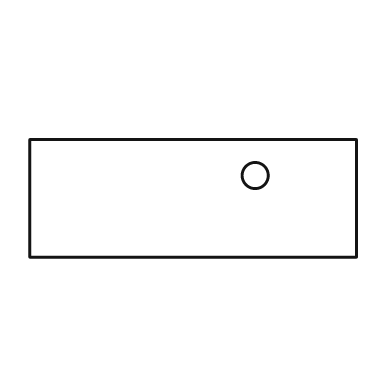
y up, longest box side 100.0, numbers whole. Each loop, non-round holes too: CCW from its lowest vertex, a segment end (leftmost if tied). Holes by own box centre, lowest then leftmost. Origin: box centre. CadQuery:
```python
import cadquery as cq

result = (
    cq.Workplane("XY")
    .moveTo(-50.0, -18.0)
    .lineTo(50.0, -18.0)
    .lineTo(50.0, 18.0)
    .lineTo(-50.0, 18.0)
    .close()
    .moveTo(19.0, 7.0)
    .circle(4.0)
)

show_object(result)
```